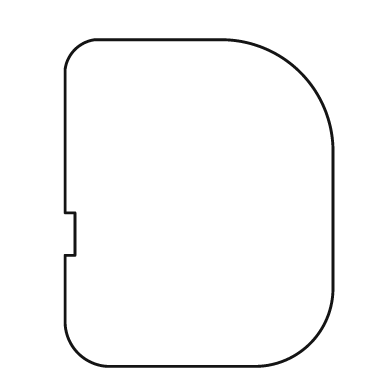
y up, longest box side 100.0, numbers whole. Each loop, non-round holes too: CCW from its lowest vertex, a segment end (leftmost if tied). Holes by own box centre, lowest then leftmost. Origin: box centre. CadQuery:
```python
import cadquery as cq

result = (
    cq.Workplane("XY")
    .moveTo(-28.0, -50.0)
    .lineTo(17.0, -50.0)
    .threePointArc((34.0, -43.0), (41.0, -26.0))
    .lineTo(41.0, 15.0)
    .threePointArc((31.0, 40.0), (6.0, 50.0))
    .lineTo(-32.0, 50.0)
    .threePointArc((-38.0, 47.0), (-41.0, 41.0))
    .lineTo(-41.0, -3.0)
    .lineTo(-38.0, -3.0)
    .lineTo(-38.0, -16.0)
    .lineTo(-41.0, -16.0)
    .lineTo(-41.0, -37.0)
    .threePointArc((-37.0, -46.0), (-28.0, -50.0))
    .close()
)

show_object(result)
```